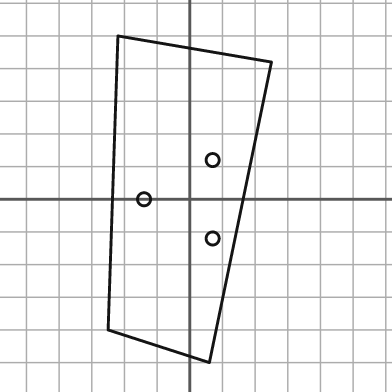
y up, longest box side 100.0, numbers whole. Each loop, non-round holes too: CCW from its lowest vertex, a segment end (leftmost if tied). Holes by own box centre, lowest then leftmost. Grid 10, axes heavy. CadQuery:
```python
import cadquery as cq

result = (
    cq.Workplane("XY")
    .moveTo(6.0, -50.0)
    .lineTo(25.0, 42.0)
    .lineTo(-22.0, 50.0)
    .lineTo(-25.0, -40.0)
    .close()
    .moveTo(7.0, -12.0)
    .circle(2.0)
    .moveTo(-14.0, 0.0)
    .circle(2.0)
    .moveTo(7.0, 12.0)
    .circle(2.0)
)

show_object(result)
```